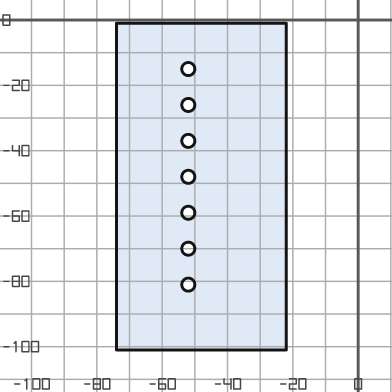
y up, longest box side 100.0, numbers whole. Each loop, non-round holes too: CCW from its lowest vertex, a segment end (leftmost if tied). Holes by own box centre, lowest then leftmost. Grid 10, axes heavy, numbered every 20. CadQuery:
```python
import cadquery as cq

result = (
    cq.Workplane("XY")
    .moveTo(-74.0, -101.0)
    .lineTo(-22.0, -101.0)
    .lineTo(-22.0, -1.0)
    .lineTo(-74.0, -1.0)
    .close()
    .moveTo(-52.0, -81.0)
    .circle(2.0)
    .moveTo(-52.0, -70.0)
    .circle(2.0)
    .moveTo(-52.0, -59.0)
    .circle(2.0)
    .moveTo(-52.0, -48.0)
    .circle(2.0)
    .moveTo(-52.0, -37.0)
    .circle(2.0)
    .moveTo(-52.0, -26.0)
    .circle(2.0)
    .moveTo(-52.0, -15.0)
    .circle(2.0)
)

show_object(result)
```